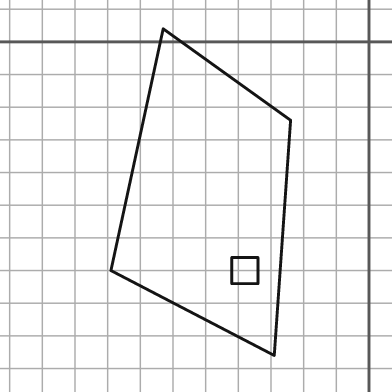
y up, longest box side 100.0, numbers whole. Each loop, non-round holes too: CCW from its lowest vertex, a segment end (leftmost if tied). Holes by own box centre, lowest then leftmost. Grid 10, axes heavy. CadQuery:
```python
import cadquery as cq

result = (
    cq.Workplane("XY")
    .moveTo(-29.0, -96.0)
    .lineTo(-24.0, -24.0)
    .lineTo(-63.0, 4.0)
    .lineTo(-79.0, -70.0)
    .close()
    .moveTo(-42.0, -74.0)
    .lineTo(-34.0, -74.0)
    .lineTo(-34.0, -66.0)
    .lineTo(-42.0, -66.0)
    .close()
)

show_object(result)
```